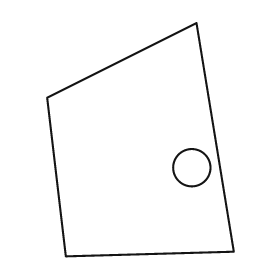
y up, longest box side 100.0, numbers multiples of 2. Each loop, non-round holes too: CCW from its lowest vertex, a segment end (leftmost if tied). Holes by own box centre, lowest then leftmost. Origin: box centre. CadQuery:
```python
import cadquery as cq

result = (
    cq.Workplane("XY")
    .moveTo(-32.0, -50.0)
    .lineTo(40.0, -48.0)
    .lineTo(24.0, 50.0)
    .lineTo(-40.0, 18.0)
    .close()
    .moveTo(22.0, -12.0)
    .circle(8.0)
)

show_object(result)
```